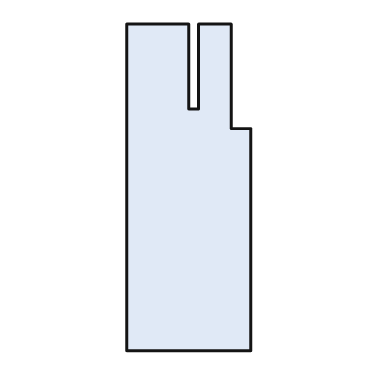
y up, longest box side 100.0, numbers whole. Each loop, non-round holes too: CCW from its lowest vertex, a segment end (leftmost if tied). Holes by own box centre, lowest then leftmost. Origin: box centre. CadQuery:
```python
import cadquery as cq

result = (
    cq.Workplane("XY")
    .moveTo(-19.0, -50.0)
    .lineTo(19.0, -50.0)
    .lineTo(19.0, 18.0)
    .lineTo(13.0, 18.0)
    .lineTo(13.0, 50.0)
    .lineTo(3.0, 50.0)
    .lineTo(3.0, 24.0)
    .lineTo(0.0, 24.0)
    .lineTo(0.0, 50.0)
    .lineTo(-19.0, 50.0)
    .close()
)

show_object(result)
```